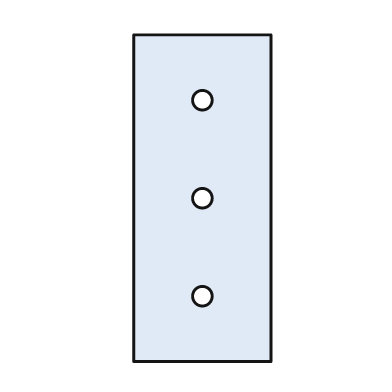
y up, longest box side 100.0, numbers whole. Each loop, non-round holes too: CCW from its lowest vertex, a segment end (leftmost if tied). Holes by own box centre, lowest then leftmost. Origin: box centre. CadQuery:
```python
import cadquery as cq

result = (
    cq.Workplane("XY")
    .moveTo(-21.0, -50.0)
    .lineTo(21.0, -50.0)
    .lineTo(21.0, 50.0)
    .lineTo(-21.0, 50.0)
    .close()
    .moveTo(0.0, -30.0)
    .circle(3.0)
    .moveTo(0.0, 0.0)
    .circle(3.0)
    .moveTo(0.0, 30.0)
    .circle(3.0)
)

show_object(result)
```